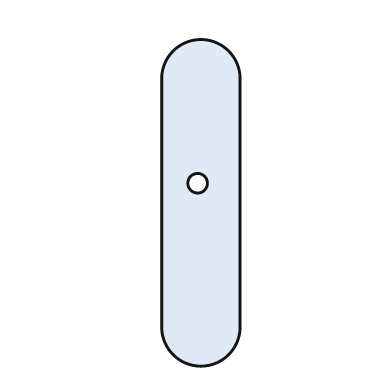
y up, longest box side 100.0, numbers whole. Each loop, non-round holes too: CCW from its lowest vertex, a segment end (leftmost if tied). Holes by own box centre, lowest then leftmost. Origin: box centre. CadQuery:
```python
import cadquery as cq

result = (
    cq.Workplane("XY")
    .moveTo(-12.0, -38.0)
    .threePointArc((0.0, -50.0), (12.0, -38.0))
    .lineTo(12.0, 38.0)
    .threePointArc((0.0, 50.0), (-12.0, 38.0))
    .close()
    .moveTo(-1.0, 6.0)
    .circle(3.0)
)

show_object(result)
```